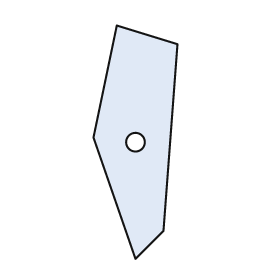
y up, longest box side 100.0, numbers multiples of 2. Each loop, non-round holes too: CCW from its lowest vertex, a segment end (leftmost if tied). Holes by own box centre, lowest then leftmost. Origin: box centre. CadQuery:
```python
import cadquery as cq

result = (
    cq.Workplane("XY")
    .moveTo(0.0, -50.0)
    .lineTo(12.0, -38.0)
    .lineTo(18.0, 42.0)
    .lineTo(-8.0, 50.0)
    .lineTo(-18.0, 2.0)
    .close()
    .moveTo(0.0, 0.0)
    .circle(4.0)
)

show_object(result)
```